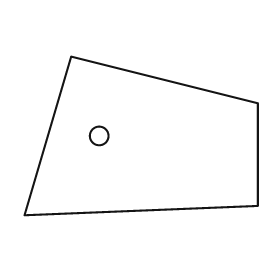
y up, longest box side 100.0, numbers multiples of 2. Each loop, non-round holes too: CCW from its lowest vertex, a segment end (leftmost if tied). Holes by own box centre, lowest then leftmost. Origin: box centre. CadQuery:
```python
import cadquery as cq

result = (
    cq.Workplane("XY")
    .moveTo(-50.0, -34.0)
    .lineTo(50.0, -30.0)
    .lineTo(50.0, 14.0)
    .lineTo(-30.0, 34.0)
    .close()
    .moveTo(-18.0, 0.0)
    .circle(4.0)
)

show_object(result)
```